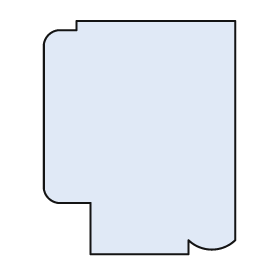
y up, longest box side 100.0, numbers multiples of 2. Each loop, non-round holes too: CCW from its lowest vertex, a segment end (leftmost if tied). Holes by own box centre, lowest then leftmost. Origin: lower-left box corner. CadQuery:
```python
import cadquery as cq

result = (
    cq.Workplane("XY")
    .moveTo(20.0, 0.0)
    .lineTo(62.0, 0.0)
    .lineTo(62.0, 6.0)
    .threePointArc((72.0, 2.0), (82.0, 6.0))
    .lineTo(82.0, 100.0)
    .lineTo(14.0, 100.0)
    .lineTo(14.0, 96.0)
    .lineTo(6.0, 96.0)
    .threePointArc((2.0, 94.0), (0.0, 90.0))
    .lineTo(0.0, 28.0)
    .threePointArc((2.0, 24.0), (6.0, 22.0))
    .lineTo(20.0, 22.0)
    .close()
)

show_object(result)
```